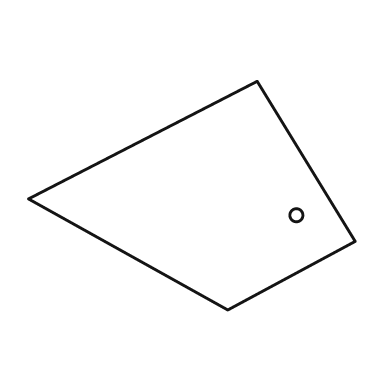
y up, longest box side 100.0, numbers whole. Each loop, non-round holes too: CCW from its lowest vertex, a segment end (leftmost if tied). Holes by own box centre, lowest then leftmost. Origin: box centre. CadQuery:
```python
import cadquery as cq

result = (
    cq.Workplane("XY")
    .moveTo(11.0, -35.0)
    .lineTo(50.0, -14.0)
    .lineTo(20.0, 35.0)
    .lineTo(-50.0, -1.0)
    .close()
    .moveTo(32.0, -6.0)
    .circle(2.0)
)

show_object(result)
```